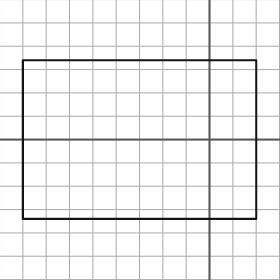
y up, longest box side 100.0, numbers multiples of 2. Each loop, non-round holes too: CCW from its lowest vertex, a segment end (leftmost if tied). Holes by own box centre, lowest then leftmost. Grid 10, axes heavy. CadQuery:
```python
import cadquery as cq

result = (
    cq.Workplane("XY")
    .moveTo(-80.0, -34.0)
    .lineTo(20.0, -34.0)
    .lineTo(20.0, 34.0)
    .lineTo(-80.0, 34.0)
    .close()
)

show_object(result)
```